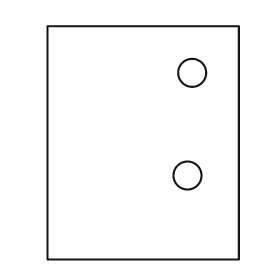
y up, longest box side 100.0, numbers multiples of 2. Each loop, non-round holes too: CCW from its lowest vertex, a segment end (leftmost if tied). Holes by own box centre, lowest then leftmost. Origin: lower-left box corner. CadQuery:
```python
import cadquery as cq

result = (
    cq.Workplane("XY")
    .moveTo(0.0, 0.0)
    .lineTo(82.0, 0.0)
    .lineTo(82.0, 100.0)
    .lineTo(0.0, 100.0)
    .close()
    .moveTo(60.0, 36.0)
    .circle(6.0)
    .moveTo(62.0, 80.0)
    .circle(6.0)
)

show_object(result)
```